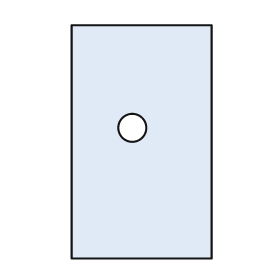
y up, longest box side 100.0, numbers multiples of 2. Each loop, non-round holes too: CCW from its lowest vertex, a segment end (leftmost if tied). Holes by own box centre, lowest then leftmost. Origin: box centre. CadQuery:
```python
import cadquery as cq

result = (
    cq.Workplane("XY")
    .moveTo(-30.0, -50.0)
    .lineTo(30.0, -50.0)
    .lineTo(30.0, 50.0)
    .lineTo(-30.0, 50.0)
    .close()
    .moveTo(-4.0, 6.0)
    .circle(6.0)
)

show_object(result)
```